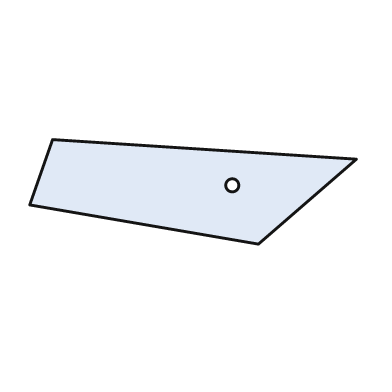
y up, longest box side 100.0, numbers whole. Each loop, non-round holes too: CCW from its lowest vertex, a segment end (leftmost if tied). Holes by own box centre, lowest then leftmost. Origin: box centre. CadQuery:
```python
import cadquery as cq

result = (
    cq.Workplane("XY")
    .moveTo(20.0, -16.0)
    .lineTo(50.0, 10.0)
    .lineTo(-43.0, 16.0)
    .lineTo(-50.0, -4.0)
    .close()
    .moveTo(12.0, 2.0)
    .circle(2.0)
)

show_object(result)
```